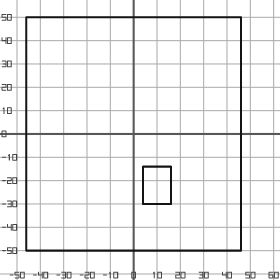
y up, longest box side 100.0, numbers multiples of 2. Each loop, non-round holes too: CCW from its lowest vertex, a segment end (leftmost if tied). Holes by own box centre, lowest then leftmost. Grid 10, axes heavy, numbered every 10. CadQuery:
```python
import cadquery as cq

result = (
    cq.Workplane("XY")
    .moveTo(-46.0, -50.0)
    .lineTo(46.0, -50.0)
    .lineTo(46.0, 50.0)
    .lineTo(-46.0, 50.0)
    .close()
    .moveTo(4.0, -30.0)
    .lineTo(16.0, -30.0)
    .lineTo(16.0, -14.0)
    .lineTo(4.0, -14.0)
    .close()
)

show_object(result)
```